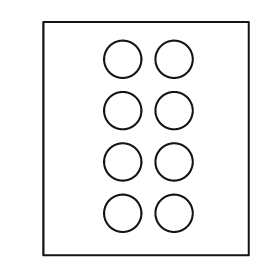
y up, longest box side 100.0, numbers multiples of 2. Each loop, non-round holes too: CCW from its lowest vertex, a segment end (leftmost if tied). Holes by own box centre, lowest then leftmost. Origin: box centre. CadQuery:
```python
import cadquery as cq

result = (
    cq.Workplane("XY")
    .moveTo(-44.0, -50.0)
    .lineTo(44.0, -50.0)
    .lineTo(44.0, 50.0)
    .lineTo(-44.0, 50.0)
    .close()
    .moveTo(-10.0, -32.0)
    .circle(8.0)
    .moveTo(12.0, -32.0)
    .circle(8.0)
    .moveTo(-10.0, -10.0)
    .circle(8.0)
    .moveTo(12.0, -10.0)
    .circle(8.0)
    .moveTo(-10.0, 12.0)
    .circle(8.0)
    .moveTo(12.0, 12.0)
    .circle(8.0)
    .moveTo(-10.0, 34.0)
    .circle(8.0)
    .moveTo(12.0, 34.0)
    .circle(8.0)
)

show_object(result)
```